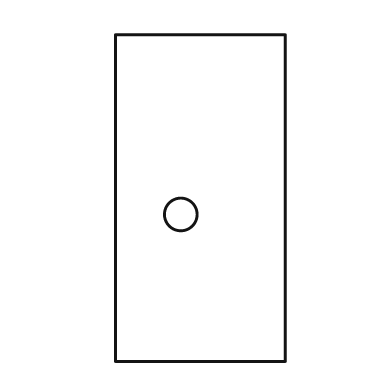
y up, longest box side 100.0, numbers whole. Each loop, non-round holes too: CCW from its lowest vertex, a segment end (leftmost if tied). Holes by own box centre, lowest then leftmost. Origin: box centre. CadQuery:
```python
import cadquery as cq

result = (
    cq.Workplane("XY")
    .moveTo(-26.0, -50.0)
    .lineTo(26.0, -50.0)
    .lineTo(26.0, 50.0)
    .lineTo(-26.0, 50.0)
    .close()
    .moveTo(-6.0, -5.0)
    .circle(5.0)
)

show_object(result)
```